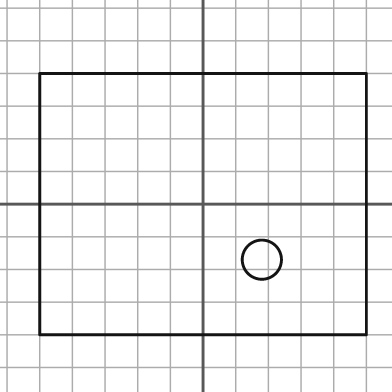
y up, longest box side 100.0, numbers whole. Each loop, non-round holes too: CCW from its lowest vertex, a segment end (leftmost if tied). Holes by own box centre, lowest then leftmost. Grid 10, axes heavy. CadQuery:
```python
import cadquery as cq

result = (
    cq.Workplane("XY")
    .moveTo(-50.0, -40.0)
    .lineTo(50.0, -40.0)
    .lineTo(50.0, 40.0)
    .lineTo(-50.0, 40.0)
    .close()
    .moveTo(18.0, -17.0)
    .circle(6.0)
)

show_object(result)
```